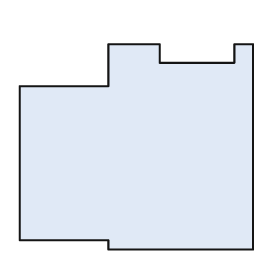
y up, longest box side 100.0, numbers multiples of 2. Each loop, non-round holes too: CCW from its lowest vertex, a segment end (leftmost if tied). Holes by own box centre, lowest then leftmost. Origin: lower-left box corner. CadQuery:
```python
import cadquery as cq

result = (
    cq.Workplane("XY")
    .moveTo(38.0, 0.0)
    .lineTo(100.0, 0.0)
    .lineTo(100.0, 88.0)
    .lineTo(92.0, 88.0)
    .lineTo(92.0, 80.0)
    .lineTo(60.0, 80.0)
    .lineTo(60.0, 88.0)
    .lineTo(38.0, 88.0)
    .lineTo(38.0, 70.0)
    .lineTo(0.0, 70.0)
    .lineTo(0.0, 4.0)
    .lineTo(38.0, 4.0)
    .close()
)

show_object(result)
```